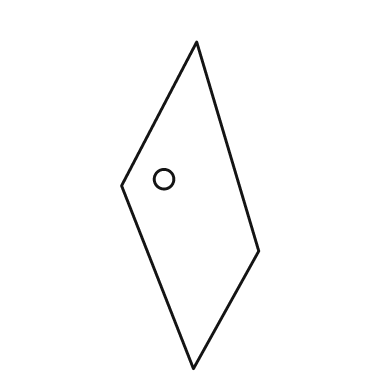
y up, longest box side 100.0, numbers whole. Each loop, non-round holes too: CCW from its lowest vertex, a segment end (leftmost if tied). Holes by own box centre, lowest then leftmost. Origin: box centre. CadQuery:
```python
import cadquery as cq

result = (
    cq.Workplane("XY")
    .moveTo(1.0, -50.0)
    .lineTo(21.0, -14.0)
    .lineTo(2.0, 50.0)
    .lineTo(-21.0, 6.0)
    .close()
    .moveTo(-8.0, 8.0)
    .circle(3.0)
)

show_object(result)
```